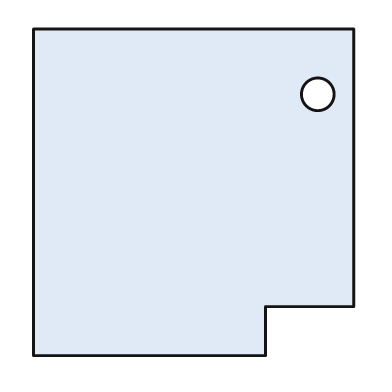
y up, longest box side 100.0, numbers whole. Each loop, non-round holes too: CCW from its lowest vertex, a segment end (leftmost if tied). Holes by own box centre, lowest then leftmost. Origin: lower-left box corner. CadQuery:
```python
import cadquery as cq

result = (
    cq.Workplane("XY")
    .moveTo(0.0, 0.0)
    .lineTo(71.0, 0.0)
    .lineTo(71.0, 15.0)
    .lineTo(98.0, 15.0)
    .lineTo(98.0, 100.0)
    .lineTo(0.0, 100.0)
    .close()
    .moveTo(87.0, 80.0)
    .circle(5.0)
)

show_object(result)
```